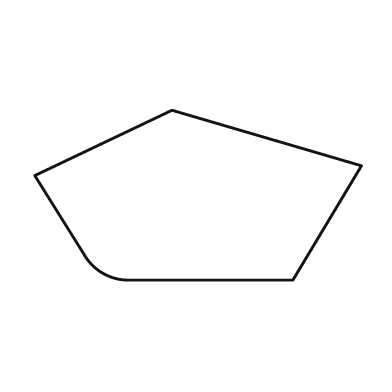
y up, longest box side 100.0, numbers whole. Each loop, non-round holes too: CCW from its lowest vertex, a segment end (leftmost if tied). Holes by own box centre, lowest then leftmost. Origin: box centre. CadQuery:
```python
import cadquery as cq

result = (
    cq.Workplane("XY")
    .moveTo(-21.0, -26.0)
    .lineTo(29.0, -26.0)
    .lineTo(50.0, 9.0)
    .lineTo(-8.0, 26.0)
    .lineTo(-50.0, 6.0)
    .lineTo(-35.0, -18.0)
    .threePointArc((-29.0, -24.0), (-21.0, -26.0))
    .close()
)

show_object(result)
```